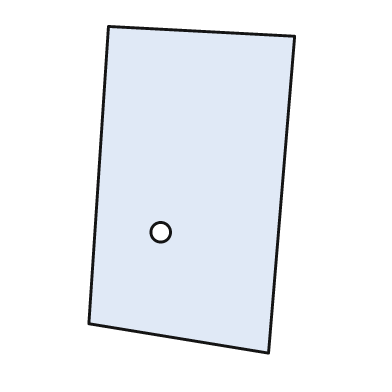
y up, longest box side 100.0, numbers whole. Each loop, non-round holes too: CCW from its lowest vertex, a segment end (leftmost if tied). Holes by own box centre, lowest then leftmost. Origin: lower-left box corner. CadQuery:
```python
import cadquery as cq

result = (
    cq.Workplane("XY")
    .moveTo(55.0, 0.0)
    .lineTo(63.0, 97.0)
    .lineTo(6.0, 100.0)
    .lineTo(0.0, 9.0)
    .close()
    .moveTo(22.0, 37.0)
    .circle(3.0)
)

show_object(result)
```